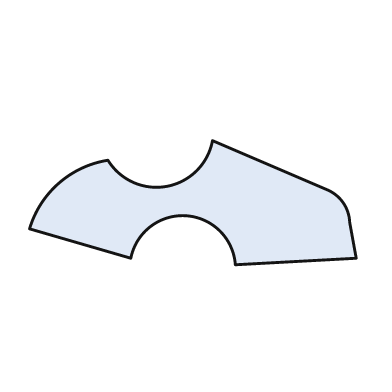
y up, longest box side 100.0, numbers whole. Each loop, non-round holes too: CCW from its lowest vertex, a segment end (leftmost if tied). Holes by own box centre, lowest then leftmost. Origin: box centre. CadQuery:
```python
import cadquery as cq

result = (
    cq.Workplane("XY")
    .moveTo(13.0, -19.0)
    .lineTo(50.0, -17.0)
    .lineTo(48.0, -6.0)
    .threePointArc((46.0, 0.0), (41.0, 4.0))
    .lineTo(6.0, 19.0)
    .threePointArc((-8.0, 5.0), (-26.0, 13.0))
    .threePointArc((-41.0, 6.0), (-50.0, -8.0))
    .lineTo(-19.0, -17.0)
    .threePointArc((-2.0, -4.0), (13.0, -19.0))
    .close()
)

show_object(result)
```